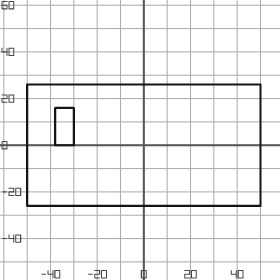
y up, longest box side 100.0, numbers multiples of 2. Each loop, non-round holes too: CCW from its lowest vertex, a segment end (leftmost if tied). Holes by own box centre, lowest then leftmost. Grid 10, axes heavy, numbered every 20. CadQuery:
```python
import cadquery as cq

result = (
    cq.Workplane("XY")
    .moveTo(-50.0, -26.0)
    .lineTo(50.0, -26.0)
    .lineTo(50.0, 26.0)
    .lineTo(-50.0, 26.0)
    .close()
    .moveTo(-38.0, 0.0)
    .lineTo(-30.0, 0.0)
    .lineTo(-30.0, 16.0)
    .lineTo(-38.0, 16.0)
    .close()
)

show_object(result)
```